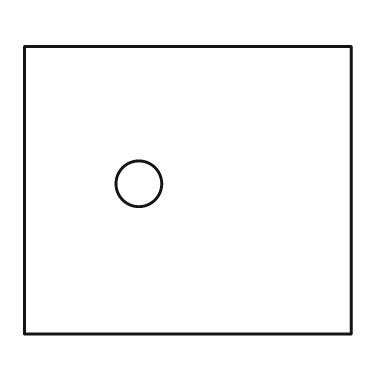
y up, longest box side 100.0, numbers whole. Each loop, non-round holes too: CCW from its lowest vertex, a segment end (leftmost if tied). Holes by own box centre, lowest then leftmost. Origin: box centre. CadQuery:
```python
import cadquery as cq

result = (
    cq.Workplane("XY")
    .moveTo(-50.0, -44.0)
    .lineTo(50.0, -44.0)
    .lineTo(50.0, 44.0)
    .lineTo(-50.0, 44.0)
    .close()
    .moveTo(-15.0, 2.0)
    .circle(7.0)
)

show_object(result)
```